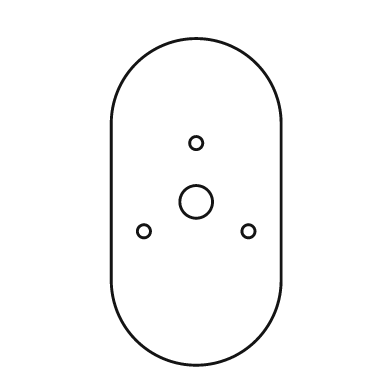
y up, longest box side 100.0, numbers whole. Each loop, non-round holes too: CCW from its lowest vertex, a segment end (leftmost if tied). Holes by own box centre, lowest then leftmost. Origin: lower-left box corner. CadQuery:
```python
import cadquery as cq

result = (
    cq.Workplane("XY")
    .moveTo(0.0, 26.0)
    .threePointArc((26.0, 0.0), (52.0, 26.0))
    .lineTo(52.0, 74.0)
    .threePointArc((26.0, 100.0), (0.0, 74.0))
    .close()
    .moveTo(10.0, 41.0)
    .circle(2.0)
    .moveTo(42.0, 41.0)
    .circle(2.0)
    .moveTo(26.0, 50.0)
    .circle(5.0)
    .moveTo(26.0, 68.0)
    .circle(2.0)
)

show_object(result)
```